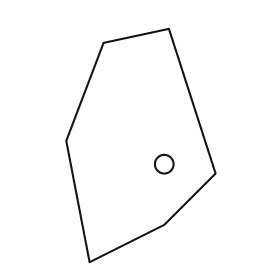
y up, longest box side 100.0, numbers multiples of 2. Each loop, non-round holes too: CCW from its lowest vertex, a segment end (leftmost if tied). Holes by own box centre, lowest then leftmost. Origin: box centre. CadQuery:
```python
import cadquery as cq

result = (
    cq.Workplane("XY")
    .moveTo(-22.0, -50.0)
    .lineTo(10.0, -34.0)
    .lineTo(32.0, -12.0)
    .lineTo(12.0, 50.0)
    .lineTo(-16.0, 44.0)
    .lineTo(-32.0, 2.0)
    .close()
    .moveTo(10.0, -8.0)
    .circle(4.0)
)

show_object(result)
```